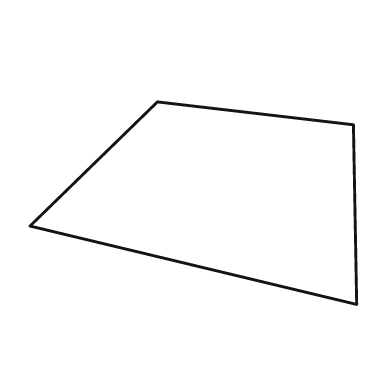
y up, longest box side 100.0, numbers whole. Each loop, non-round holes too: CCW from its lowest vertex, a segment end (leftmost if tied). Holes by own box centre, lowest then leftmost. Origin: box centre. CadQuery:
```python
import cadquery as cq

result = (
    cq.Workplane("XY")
    .moveTo(50.0, -31.0)
    .lineTo(49.0, 24.0)
    .lineTo(-11.0, 31.0)
    .lineTo(-50.0, -7.0)
    .close()
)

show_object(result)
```